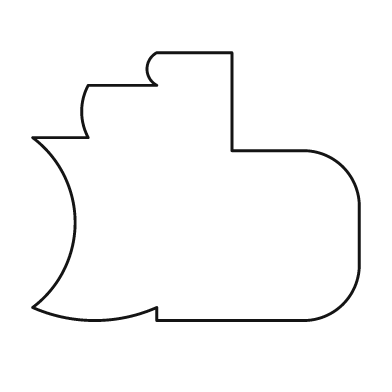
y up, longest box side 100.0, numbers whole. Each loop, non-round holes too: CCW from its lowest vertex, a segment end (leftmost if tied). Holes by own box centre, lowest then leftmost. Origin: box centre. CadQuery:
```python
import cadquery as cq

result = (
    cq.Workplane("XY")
    .moveTo(-12.0, -41.0)
    .lineTo(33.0, -41.0)
    .threePointArc((45.0, -36.0), (50.0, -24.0))
    .lineTo(50.0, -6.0)
    .threePointArc((45.0, 6.0), (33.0, 11.0))
    .lineTo(11.0, 11.0)
    .lineTo(11.0, 41.0)
    .lineTo(-12.0, 41.0)
    .threePointArc((-15.0, 36.0), (-12.0, 31.0))
    .lineTo(-33.0, 31.0)
    .threePointArc((-35.0, 23.0), (-33.0, 15.0))
    .lineTo(-50.0, 15.0)
    .threePointArc((-37.0, -11.0), (-50.0, -37.0))
    .threePointArc((-31.0, -41.0), (-12.0, -37.0))
    .close()
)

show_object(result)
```